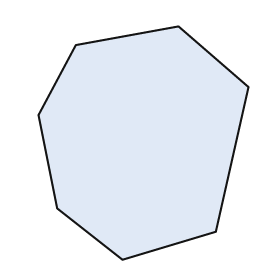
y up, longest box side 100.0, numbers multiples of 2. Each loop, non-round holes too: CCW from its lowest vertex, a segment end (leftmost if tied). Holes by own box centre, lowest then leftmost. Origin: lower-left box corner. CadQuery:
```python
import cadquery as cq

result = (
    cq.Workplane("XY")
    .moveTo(36.0, 0.0)
    .lineTo(76.0, 12.0)
    .lineTo(90.0, 74.0)
    .lineTo(60.0, 100.0)
    .lineTo(16.0, 92.0)
    .lineTo(0.0, 62.0)
    .lineTo(8.0, 22.0)
    .close()
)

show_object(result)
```